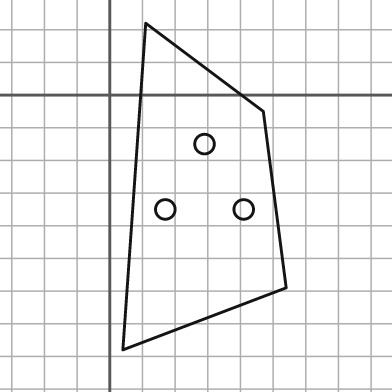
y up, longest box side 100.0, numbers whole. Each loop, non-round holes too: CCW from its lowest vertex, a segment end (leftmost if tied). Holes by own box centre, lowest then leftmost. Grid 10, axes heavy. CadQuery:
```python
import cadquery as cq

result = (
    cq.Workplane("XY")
    .moveTo(4.0, -78.0)
    .lineTo(54.0, -59.0)
    .lineTo(47.0, -5.0)
    .lineTo(11.0, 22.0)
    .close()
    .moveTo(17.0, -35.0)
    .circle(3.0)
    .moveTo(41.0, -35.0)
    .circle(3.0)
    .moveTo(29.0, -15.0)
    .circle(3.0)
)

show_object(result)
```